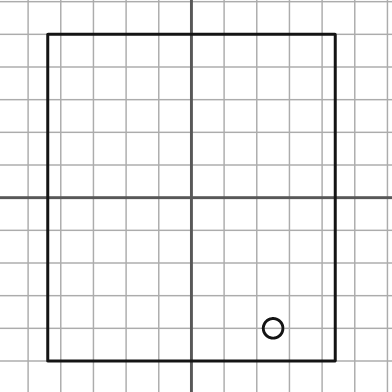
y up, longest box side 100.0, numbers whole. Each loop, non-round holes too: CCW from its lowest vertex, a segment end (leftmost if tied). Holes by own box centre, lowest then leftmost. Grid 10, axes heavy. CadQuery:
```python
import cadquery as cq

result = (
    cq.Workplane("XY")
    .moveTo(-44.0, -50.0)
    .lineTo(44.0, -50.0)
    .lineTo(44.0, 50.0)
    .lineTo(-44.0, 50.0)
    .close()
    .moveTo(25.0, -40.0)
    .circle(3.0)
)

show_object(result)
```